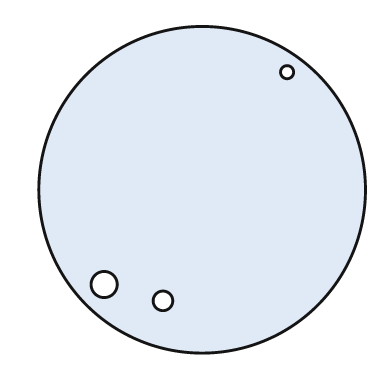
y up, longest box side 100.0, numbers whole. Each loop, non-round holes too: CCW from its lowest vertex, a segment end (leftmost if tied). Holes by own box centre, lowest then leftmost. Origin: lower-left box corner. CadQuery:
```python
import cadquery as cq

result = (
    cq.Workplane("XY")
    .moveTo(50.0, 50.0)
    .circle(50.0)
    .moveTo(38.0, 16.0)
    .circle(3.0)
    .moveTo(20.0, 21.0)
    .circle(4.0)
    .moveTo(76.0, 86.0)
    .circle(2.0)
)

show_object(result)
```